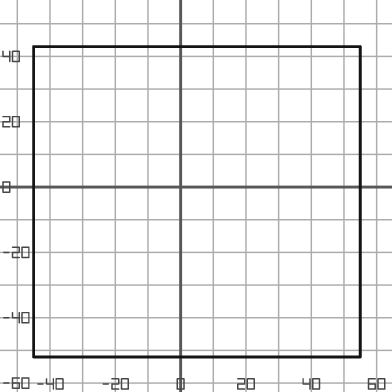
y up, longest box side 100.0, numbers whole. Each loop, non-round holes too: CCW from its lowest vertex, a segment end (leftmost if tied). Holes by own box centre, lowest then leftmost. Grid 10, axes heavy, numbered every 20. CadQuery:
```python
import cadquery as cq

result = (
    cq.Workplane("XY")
    .moveTo(-45.0, -52.0)
    .lineTo(55.0, -52.0)
    .lineTo(55.0, 43.0)
    .lineTo(-45.0, 43.0)
    .close()
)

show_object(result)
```